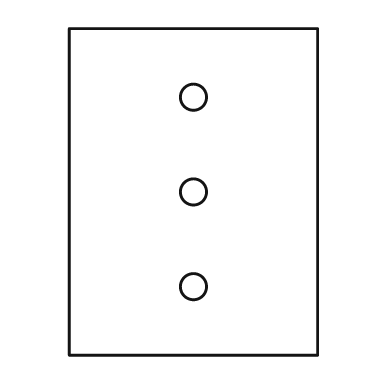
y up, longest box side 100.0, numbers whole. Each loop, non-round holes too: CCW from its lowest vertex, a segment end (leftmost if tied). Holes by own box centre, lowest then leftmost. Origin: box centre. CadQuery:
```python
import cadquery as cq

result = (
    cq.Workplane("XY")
    .moveTo(-38.0, -50.0)
    .lineTo(38.0, -50.0)
    .lineTo(38.0, 50.0)
    .lineTo(-38.0, 50.0)
    .close()
    .moveTo(0.0, -29.0)
    .circle(4.0)
    .moveTo(0.0, 0.0)
    .circle(4.0)
    .moveTo(0.0, 29.0)
    .circle(4.0)
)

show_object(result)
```